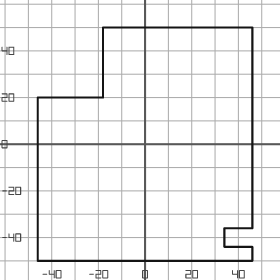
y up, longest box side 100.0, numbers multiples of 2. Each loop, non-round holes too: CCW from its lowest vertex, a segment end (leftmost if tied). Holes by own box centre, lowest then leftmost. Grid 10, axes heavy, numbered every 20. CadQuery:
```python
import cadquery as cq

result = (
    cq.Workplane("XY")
    .moveTo(-46.0, -50.0)
    .lineTo(46.0, -50.0)
    .lineTo(46.0, -44.0)
    .lineTo(34.0, -44.0)
    .lineTo(34.0, -36.0)
    .lineTo(46.0, -36.0)
    .lineTo(46.0, 50.0)
    .lineTo(-18.0, 50.0)
    .lineTo(-18.0, 20.0)
    .lineTo(-46.0, 20.0)
    .close()
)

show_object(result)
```